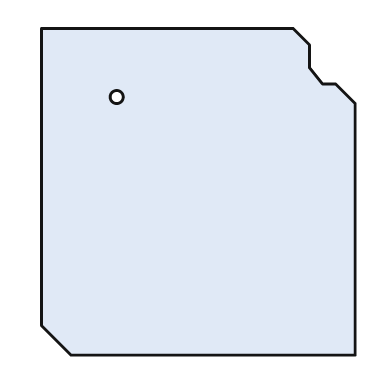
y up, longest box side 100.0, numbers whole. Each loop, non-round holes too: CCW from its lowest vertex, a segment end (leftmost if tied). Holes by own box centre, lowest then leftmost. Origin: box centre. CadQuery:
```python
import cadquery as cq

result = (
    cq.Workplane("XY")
    .moveTo(-39.0, -50.0)
    .lineTo(48.0, -50.0)
    .lineTo(48.0, 27.0)
    .lineTo(42.0, 33.0)
    .lineTo(38.0, 33.0)
    .lineTo(34.0, 38.0)
    .lineTo(34.0, 45.0)
    .lineTo(29.0, 50.0)
    .lineTo(-48.0, 50.0)
    .lineTo(-48.0, -41.0)
    .close()
    .moveTo(-25.0, 29.0)
    .circle(2.0)
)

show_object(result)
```